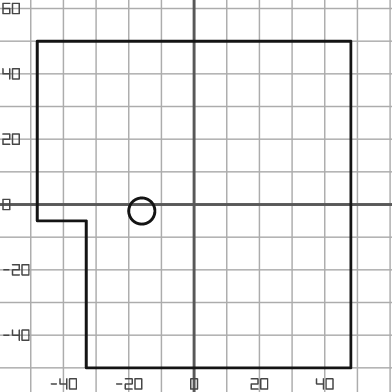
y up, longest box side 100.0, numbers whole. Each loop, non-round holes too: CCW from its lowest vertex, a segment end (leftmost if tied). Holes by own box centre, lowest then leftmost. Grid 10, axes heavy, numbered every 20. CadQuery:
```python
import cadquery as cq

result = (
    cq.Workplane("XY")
    .moveTo(-33.0, -50.0)
    .lineTo(48.0, -50.0)
    .lineTo(48.0, 50.0)
    .lineTo(-48.0, 50.0)
    .lineTo(-48.0, -5.0)
    .lineTo(-33.0, -5.0)
    .close()
    .moveTo(-16.0, -2.0)
    .circle(4.0)
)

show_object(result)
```